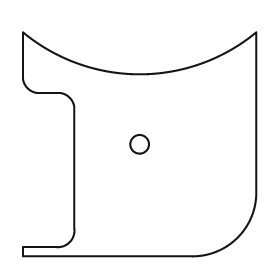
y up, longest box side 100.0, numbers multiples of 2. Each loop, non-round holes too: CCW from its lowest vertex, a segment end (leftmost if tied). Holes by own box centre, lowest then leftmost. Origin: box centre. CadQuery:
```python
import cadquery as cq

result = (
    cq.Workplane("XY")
    .moveTo(-50.0, -48.0)
    .lineTo(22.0, -48.0)
    .threePointArc((42.0, -40.0), (50.0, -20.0))
    .lineTo(50.0, 48.0)
    .threePointArc((0.0, 30.0), (-50.0, 48.0))
    .lineTo(-50.0, 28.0)
    .threePointArc((-48.0, 24.0), (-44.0, 22.0))
    .lineTo(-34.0, 22.0)
    .threePointArc((-30.0, 20.0), (-28.0, 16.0))
    .lineTo(-28.0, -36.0)
    .threePointArc((-30.0, -42.0), (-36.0, -44.0))
    .lineTo(-50.0, -44.0)
    .close()
    .moveTo(0.0, 0.0)
    .circle(4.0)
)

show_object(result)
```